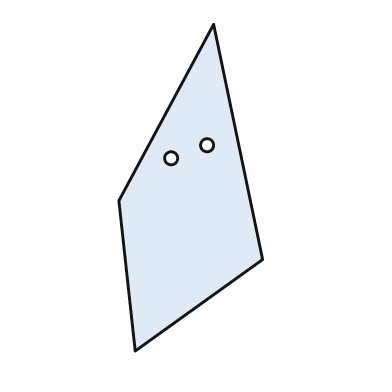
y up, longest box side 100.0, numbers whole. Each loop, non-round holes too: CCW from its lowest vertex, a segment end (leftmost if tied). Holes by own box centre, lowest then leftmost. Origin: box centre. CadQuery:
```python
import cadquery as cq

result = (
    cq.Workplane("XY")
    .moveTo(-17.0, -50.0)
    .lineTo(22.0, -22.0)
    .lineTo(7.0, 50.0)
    .lineTo(-22.0, -4.0)
    .close()
    .moveTo(-6.0, 9.0)
    .circle(2.0)
    .moveTo(5.0, 13.0)
    .circle(2.0)
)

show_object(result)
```